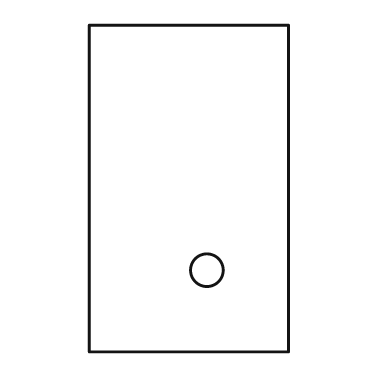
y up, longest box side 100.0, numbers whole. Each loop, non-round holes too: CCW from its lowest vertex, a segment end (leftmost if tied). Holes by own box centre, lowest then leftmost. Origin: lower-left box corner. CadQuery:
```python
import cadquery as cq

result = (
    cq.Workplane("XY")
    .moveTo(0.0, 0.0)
    .lineTo(61.0, 0.0)
    .lineTo(61.0, 100.0)
    .lineTo(0.0, 100.0)
    .close()
    .moveTo(36.0, 25.0)
    .circle(5.0)
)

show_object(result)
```